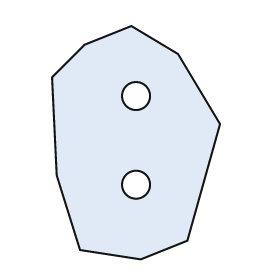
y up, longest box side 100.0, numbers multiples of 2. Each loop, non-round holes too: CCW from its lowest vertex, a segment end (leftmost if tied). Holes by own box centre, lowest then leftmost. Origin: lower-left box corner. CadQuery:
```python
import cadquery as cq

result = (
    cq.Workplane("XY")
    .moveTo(38.0, 0.0)
    .lineTo(58.0, 8.0)
    .lineTo(72.0, 58.0)
    .lineTo(54.0, 88.0)
    .lineTo(34.0, 100.0)
    .lineTo(14.0, 92.0)
    .lineTo(0.0, 78.0)
    .lineTo(2.0, 36.0)
    .lineTo(12.0, 4.0)
    .close()
    .moveTo(36.0, 32.0)
    .circle(6.0)
    .moveTo(36.0, 70.0)
    .circle(6.0)
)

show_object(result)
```